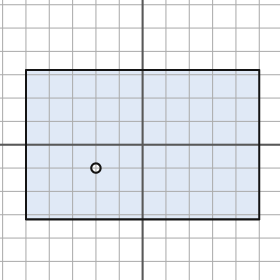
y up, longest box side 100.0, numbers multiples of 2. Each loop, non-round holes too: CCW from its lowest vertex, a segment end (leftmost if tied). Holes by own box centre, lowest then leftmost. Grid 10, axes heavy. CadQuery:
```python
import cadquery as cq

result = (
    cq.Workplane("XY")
    .moveTo(-50.0, -32.0)
    .lineTo(50.0, -32.0)
    .lineTo(50.0, 32.0)
    .lineTo(-50.0, 32.0)
    .close()
    .moveTo(-20.0, -10.0)
    .circle(2.0)
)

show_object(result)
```